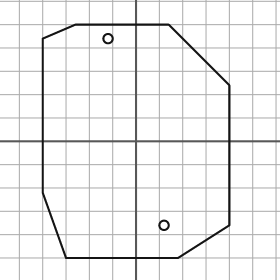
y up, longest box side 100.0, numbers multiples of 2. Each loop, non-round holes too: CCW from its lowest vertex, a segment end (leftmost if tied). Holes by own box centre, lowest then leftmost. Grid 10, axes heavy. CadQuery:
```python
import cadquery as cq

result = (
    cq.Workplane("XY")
    .moveTo(-30.0, -50.0)
    .lineTo(18.0, -50.0)
    .lineTo(40.0, -36.0)
    .lineTo(40.0, 24.0)
    .lineTo(14.0, 50.0)
    .lineTo(-26.0, 50.0)
    .lineTo(-40.0, 44.0)
    .lineTo(-40.0, -22.0)
    .close()
    .moveTo(12.0, -36.0)
    .circle(2.0)
    .moveTo(-12.0, 44.0)
    .circle(2.0)
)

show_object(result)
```